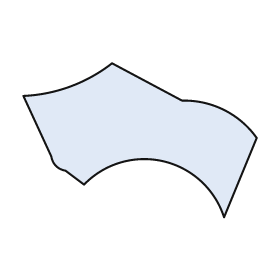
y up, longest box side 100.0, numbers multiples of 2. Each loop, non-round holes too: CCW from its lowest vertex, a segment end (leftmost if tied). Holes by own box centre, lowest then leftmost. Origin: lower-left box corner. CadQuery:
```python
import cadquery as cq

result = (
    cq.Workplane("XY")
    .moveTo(86.0, 0.0)
    .lineTo(100.0, 34.0)
    .threePointArc((86.0, 46.0), (68.0, 50.0))
    .lineTo(38.0, 66.0)
    .threePointArc((20.0, 56.0), (0.0, 52.0))
    .lineTo(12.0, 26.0)
    .threePointArc((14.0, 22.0), (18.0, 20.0))
    .lineTo(26.0, 14.0)
    .threePointArc((60.0, 24.0), (86.0, 0.0))
    .close()
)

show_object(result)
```